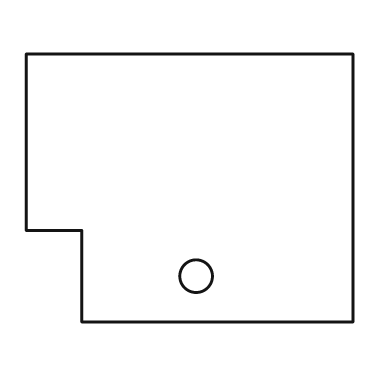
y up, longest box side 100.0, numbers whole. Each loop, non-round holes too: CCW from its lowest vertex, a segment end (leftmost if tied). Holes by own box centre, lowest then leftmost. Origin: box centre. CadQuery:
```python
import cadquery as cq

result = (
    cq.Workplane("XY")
    .moveTo(-33.0, -41.0)
    .lineTo(50.0, -41.0)
    .lineTo(50.0, 41.0)
    .lineTo(-50.0, 41.0)
    .lineTo(-50.0, -13.0)
    .lineTo(-33.0, -13.0)
    .close()
    .moveTo(2.0, -27.0)
    .circle(5.0)
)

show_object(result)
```